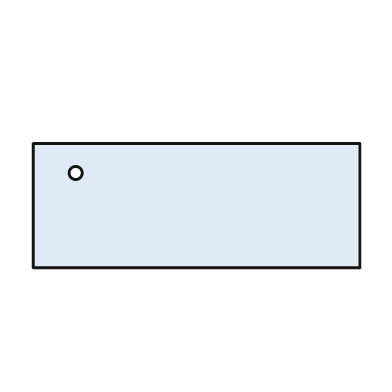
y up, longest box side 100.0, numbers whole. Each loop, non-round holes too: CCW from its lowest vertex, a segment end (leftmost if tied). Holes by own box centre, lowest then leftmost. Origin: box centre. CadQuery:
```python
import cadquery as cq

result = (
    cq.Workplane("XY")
    .moveTo(-50.0, -19.0)
    .lineTo(50.0, -19.0)
    .lineTo(50.0, 19.0)
    .lineTo(-50.0, 19.0)
    .close()
    .moveTo(-37.0, 10.0)
    .circle(2.0)
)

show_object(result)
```